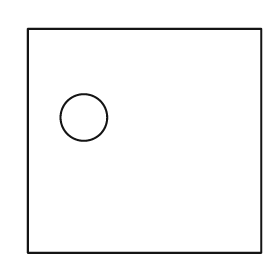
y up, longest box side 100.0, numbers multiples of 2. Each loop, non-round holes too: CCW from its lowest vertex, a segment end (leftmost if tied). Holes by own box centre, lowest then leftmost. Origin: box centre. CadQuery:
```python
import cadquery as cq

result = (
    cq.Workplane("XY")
    .moveTo(-50.0, -48.0)
    .lineTo(50.0, -48.0)
    .lineTo(50.0, 48.0)
    .lineTo(-50.0, 48.0)
    .close()
    .moveTo(-26.0, 10.0)
    .circle(10.0)
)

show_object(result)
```